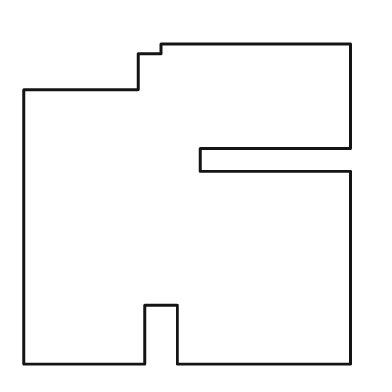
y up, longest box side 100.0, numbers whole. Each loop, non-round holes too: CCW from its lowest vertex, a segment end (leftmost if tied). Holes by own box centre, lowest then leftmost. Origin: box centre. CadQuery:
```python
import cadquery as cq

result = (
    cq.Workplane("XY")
    .moveTo(-50.0, -49.0)
    .lineTo(-13.0, -49.0)
    .lineTo(-13.0, -31.0)
    .lineTo(-3.0, -31.0)
    .lineTo(-3.0, -49.0)
    .lineTo(50.0, -49.0)
    .lineTo(50.0, 10.0)
    .lineTo(4.0, 10.0)
    .lineTo(4.0, 17.0)
    .lineTo(50.0, 17.0)
    .lineTo(50.0, 49.0)
    .lineTo(-8.0, 49.0)
    .lineTo(-8.0, 46.0)
    .lineTo(-15.0, 46.0)
    .lineTo(-15.0, 35.0)
    .lineTo(-50.0, 35.0)
    .close()
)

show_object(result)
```